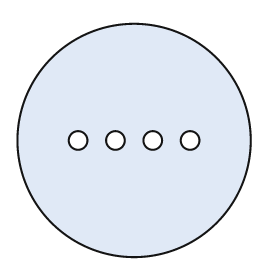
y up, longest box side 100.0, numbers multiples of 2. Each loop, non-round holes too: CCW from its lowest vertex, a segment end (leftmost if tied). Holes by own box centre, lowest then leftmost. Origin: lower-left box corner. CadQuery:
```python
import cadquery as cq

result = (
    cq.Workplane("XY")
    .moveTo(50.0, 50.0)
    .circle(50.0)
    .moveTo(26.0, 50.0)
    .circle(4.0)
    .moveTo(42.0, 50.0)
    .circle(4.0)
    .moveTo(58.0, 50.0)
    .circle(4.0)
    .moveTo(74.0, 50.0)
    .circle(4.0)
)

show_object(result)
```